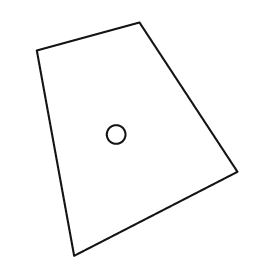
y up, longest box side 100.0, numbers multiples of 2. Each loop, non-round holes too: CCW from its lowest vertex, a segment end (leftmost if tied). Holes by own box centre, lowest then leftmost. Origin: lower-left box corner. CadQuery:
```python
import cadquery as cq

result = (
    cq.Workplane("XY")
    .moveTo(16.0, 0.0)
    .lineTo(86.0, 36.0)
    .lineTo(44.0, 100.0)
    .lineTo(0.0, 88.0)
    .close()
    .moveTo(34.0, 52.0)
    .circle(4.0)
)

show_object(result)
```